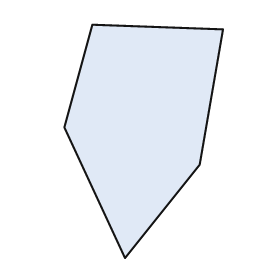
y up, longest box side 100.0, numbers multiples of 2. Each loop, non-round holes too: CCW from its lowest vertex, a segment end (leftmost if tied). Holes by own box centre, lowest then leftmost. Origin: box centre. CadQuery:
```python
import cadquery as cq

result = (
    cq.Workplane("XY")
    .moveTo(-8.0, -50.0)
    .lineTo(24.0, -10.0)
    .lineTo(34.0, 48.0)
    .lineTo(-22.0, 50.0)
    .lineTo(-34.0, 6.0)
    .close()
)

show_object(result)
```